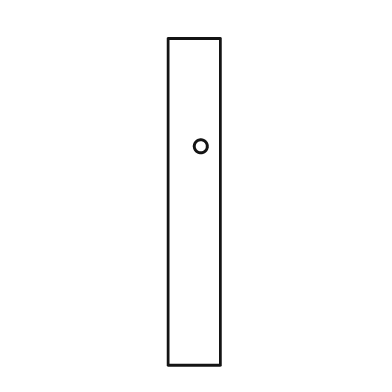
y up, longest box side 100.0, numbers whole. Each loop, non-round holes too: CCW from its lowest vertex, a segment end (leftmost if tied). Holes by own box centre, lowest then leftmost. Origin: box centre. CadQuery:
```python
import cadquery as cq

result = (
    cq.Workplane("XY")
    .moveTo(-8.0, -50.0)
    .lineTo(8.0, -50.0)
    .lineTo(8.0, 50.0)
    .lineTo(-8.0, 50.0)
    .close()
    .moveTo(2.0, 17.0)
    .circle(2.0)
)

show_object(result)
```